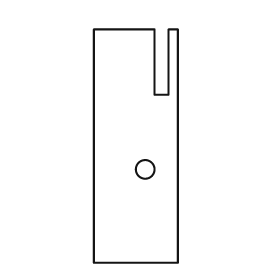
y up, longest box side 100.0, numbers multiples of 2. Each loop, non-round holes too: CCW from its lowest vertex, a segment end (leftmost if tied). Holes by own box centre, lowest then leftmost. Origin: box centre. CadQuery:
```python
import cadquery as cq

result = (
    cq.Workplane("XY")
    .moveTo(-18.0, -50.0)
    .lineTo(18.0, -50.0)
    .lineTo(18.0, 50.0)
    .lineTo(14.0, 50.0)
    .lineTo(14.0, 22.0)
    .lineTo(8.0, 22.0)
    .lineTo(8.0, 50.0)
    .lineTo(-18.0, 50.0)
    .close()
    .moveTo(4.0, -10.0)
    .circle(4.0)
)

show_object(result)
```